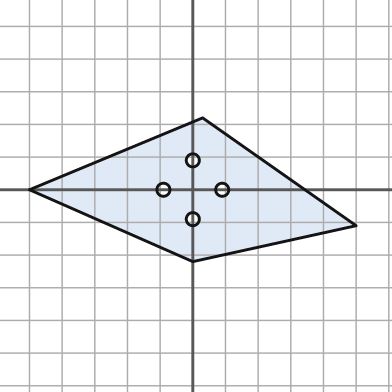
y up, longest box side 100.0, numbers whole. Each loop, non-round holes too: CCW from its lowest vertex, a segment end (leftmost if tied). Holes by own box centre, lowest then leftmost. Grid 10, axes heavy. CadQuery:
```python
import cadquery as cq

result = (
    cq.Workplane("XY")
    .moveTo(0.0, -22.0)
    .lineTo(50.0, -11.0)
    .lineTo(3.0, 22.0)
    .lineTo(-50.0, 0.0)
    .close()
    .moveTo(0.0, -9.0)
    .circle(2.0)
    .moveTo(-9.0, 0.0)
    .circle(2.0)
    .moveTo(9.0, 0.0)
    .circle(2.0)
    .moveTo(0.0, 9.0)
    .circle(2.0)
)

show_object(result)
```